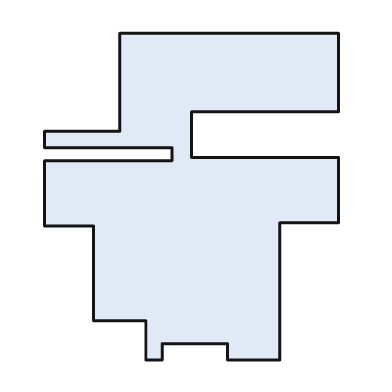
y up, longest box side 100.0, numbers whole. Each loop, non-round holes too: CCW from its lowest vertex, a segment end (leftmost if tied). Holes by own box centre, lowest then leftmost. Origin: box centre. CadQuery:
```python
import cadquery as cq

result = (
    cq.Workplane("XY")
    .moveTo(-14.0, -50.0)
    .lineTo(-9.0, -50.0)
    .lineTo(-9.0, -45.0)
    .lineTo(11.0, -45.0)
    .lineTo(11.0, -50.0)
    .lineTo(27.0, -50.0)
    .lineTo(27.0, -8.0)
    .lineTo(45.0, -8.0)
    .lineTo(45.0, 12.0)
    .lineTo(0.0, 12.0)
    .lineTo(0.0, 26.0)
    .lineTo(45.0, 26.0)
    .lineTo(45.0, 50.0)
    .lineTo(-22.0, 50.0)
    .lineTo(-22.0, 20.0)
    .lineTo(-45.0, 20.0)
    .lineTo(-45.0, 15.0)
    .lineTo(-6.0, 15.0)
    .lineTo(-6.0, 11.0)
    .lineTo(-45.0, 11.0)
    .lineTo(-45.0, -9.0)
    .lineTo(-30.0, -9.0)
    .lineTo(-30.0, -38.0)
    .lineTo(-14.0, -38.0)
    .close()
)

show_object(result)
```